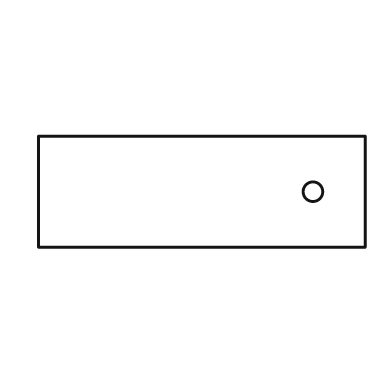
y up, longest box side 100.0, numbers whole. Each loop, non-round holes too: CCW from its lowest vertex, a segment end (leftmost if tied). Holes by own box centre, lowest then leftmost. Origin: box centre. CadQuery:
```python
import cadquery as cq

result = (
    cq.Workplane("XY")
    .moveTo(-50.0, -17.0)
    .lineTo(50.0, -17.0)
    .lineTo(50.0, 17.0)
    .lineTo(-50.0, 17.0)
    .close()
    .moveTo(34.0, 0.0)
    .circle(3.0)
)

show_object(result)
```